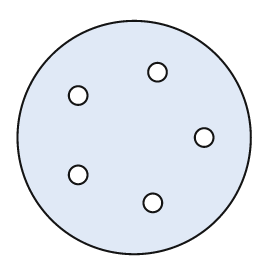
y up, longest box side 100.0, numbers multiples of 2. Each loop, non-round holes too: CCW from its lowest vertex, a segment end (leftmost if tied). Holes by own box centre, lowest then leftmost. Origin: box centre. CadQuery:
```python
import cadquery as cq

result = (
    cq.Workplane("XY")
    .moveTo(0.0, 0.0)
    .circle(50.0)
    .moveTo(8.0, -28.0)
    .circle(4.0)
    .moveTo(-24.0, -16.0)
    .circle(4.0)
    .moveTo(30.0, 0.0)
    .circle(4.0)
    .moveTo(-24.0, 18.0)
    .circle(4.0)
    .moveTo(10.0, 28.0)
    .circle(4.0)
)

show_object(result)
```